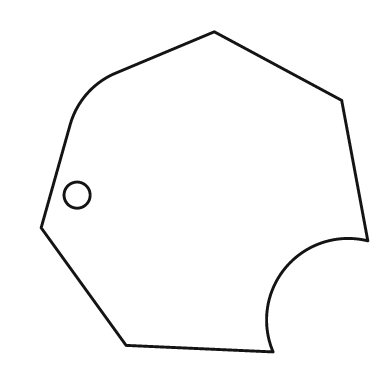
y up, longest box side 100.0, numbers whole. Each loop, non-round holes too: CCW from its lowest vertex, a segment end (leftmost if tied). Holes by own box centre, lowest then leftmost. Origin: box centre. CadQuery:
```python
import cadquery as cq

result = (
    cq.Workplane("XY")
    .moveTo(21.0, -49.0)
    .threePointArc((25.0, -23.0), (50.0, -15.0))
    .lineTo(42.0, 28.0)
    .lineTo(3.0, 49.0)
    .lineTo(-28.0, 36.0)
    .threePointArc((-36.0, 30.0), (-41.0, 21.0))
    .lineTo(-50.0, -11.0)
    .lineTo(-24.0, -47.0)
    .close()
    .moveTo(-39.0, -1.0)
    .circle(4.0)
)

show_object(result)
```